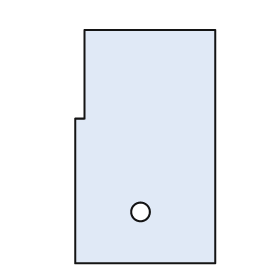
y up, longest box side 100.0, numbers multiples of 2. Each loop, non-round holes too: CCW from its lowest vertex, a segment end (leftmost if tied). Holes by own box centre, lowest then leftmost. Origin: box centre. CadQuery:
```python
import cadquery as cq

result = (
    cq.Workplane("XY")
    .moveTo(-30.0, -50.0)
    .lineTo(30.0, -50.0)
    .lineTo(30.0, 50.0)
    .lineTo(-26.0, 50.0)
    .lineTo(-26.0, 12.0)
    .lineTo(-30.0, 12.0)
    .close()
    .moveTo(-2.0, -28.0)
    .circle(4.0)
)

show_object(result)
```